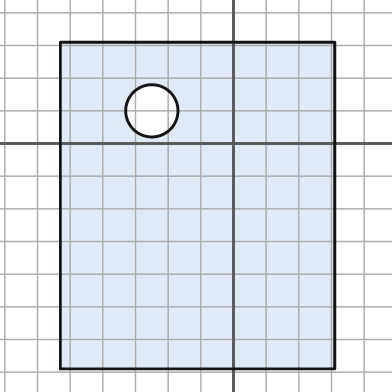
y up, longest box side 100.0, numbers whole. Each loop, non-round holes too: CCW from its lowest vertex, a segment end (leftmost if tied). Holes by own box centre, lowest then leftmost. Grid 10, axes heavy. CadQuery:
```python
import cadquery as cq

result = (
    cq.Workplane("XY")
    .moveTo(-53.0, -69.0)
    .lineTo(31.0, -69.0)
    .lineTo(31.0, 31.0)
    .lineTo(-53.0, 31.0)
    .close()
    .moveTo(-25.0, 10.0)
    .circle(8.0)
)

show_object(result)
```